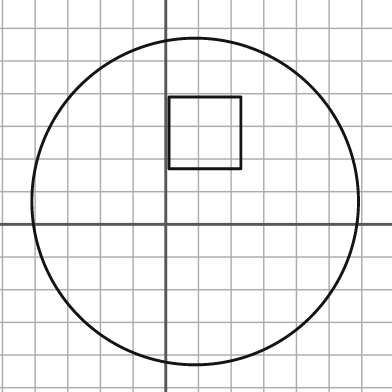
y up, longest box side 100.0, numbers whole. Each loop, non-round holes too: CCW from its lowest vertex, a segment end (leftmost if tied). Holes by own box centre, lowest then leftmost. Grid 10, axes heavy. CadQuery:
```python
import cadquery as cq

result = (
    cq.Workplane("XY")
    .moveTo(9.0, 7.0)
    .circle(50.0)
    .moveTo(1.0, 17.0)
    .lineTo(23.0, 17.0)
    .lineTo(23.0, 39.0)
    .lineTo(1.0, 39.0)
    .close()
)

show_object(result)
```